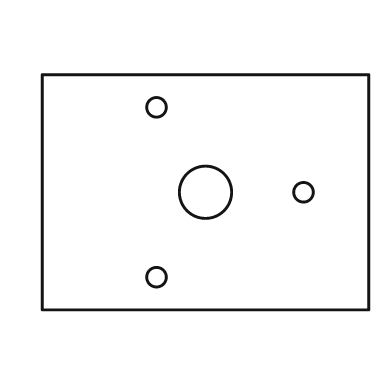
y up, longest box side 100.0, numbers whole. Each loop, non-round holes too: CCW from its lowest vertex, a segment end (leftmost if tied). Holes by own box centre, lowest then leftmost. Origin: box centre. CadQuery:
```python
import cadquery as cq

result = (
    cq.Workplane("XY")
    .moveTo(-50.0, -36.0)
    .lineTo(50.0, -36.0)
    .lineTo(50.0, 36.0)
    .lineTo(-50.0, 36.0)
    .close()
    .moveTo(-15.0, -26.0)
    .circle(3.0)
    .moveTo(0.0, 0.0)
    .circle(8.0)
    .moveTo(30.0, 0.0)
    .circle(3.0)
    .moveTo(-15.0, 26.0)
    .circle(3.0)
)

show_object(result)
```